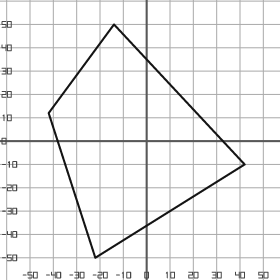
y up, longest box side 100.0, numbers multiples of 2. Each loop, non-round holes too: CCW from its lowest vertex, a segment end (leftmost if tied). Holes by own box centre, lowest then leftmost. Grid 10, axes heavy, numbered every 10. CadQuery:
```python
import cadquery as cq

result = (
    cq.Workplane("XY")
    .moveTo(-22.0, -50.0)
    .lineTo(42.0, -10.0)
    .lineTo(-14.0, 50.0)
    .lineTo(-42.0, 12.0)
    .close()
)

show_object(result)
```